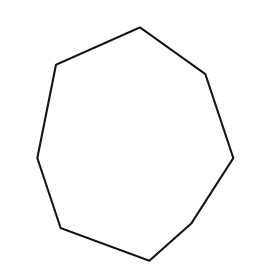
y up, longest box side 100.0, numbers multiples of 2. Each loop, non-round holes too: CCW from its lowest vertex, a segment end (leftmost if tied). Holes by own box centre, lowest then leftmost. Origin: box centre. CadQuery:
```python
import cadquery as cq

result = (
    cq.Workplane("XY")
    .moveTo(6.0, -50.0)
    .lineTo(24.0, -34.0)
    .lineTo(42.0, -6.0)
    .lineTo(30.0, 30.0)
    .lineTo(2.0, 50.0)
    .lineTo(-34.0, 34.0)
    .lineTo(-42.0, -6.0)
    .lineTo(-32.0, -36.0)
    .close()
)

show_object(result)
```